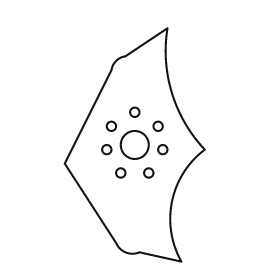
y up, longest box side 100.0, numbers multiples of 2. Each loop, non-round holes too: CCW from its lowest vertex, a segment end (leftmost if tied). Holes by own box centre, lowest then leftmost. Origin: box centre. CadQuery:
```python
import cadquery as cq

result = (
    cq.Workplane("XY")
    .moveTo(20.0, -50.0)
    .threePointArc((16.0, -24.0), (30.0, -2.0))
    .threePointArc((16.0, 22.0), (14.0, 50.0))
    .lineTo(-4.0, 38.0)
    .threePointArc((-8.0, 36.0), (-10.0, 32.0))
    .lineTo(-30.0, -8.0)
    .lineTo(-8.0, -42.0)
    .threePointArc((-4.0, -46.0), (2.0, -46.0))
    .close()
    .moveTo(-6.0, -12.0)
    .circle(2.0)
    .moveTo(6.0, -12.0)
    .circle(2.0)
    .moveTo(-12.0, -2.0)
    .circle(2.0)
    .moveTo(12.0, -2.0)
    .circle(2.0)
    .moveTo(0.0, 0.0)
    .circle(6.0)
    .moveTo(-10.0, 8.0)
    .circle(2.0)
    .moveTo(10.0, 8.0)
    .circle(2.0)
    .moveTo(0.0, 14.0)
    .circle(2.0)
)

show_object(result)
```